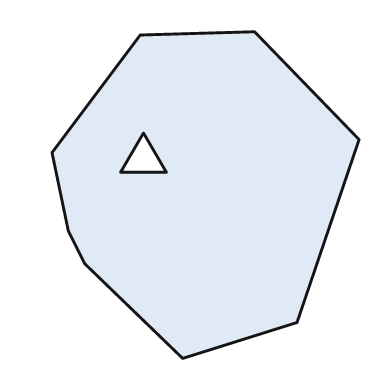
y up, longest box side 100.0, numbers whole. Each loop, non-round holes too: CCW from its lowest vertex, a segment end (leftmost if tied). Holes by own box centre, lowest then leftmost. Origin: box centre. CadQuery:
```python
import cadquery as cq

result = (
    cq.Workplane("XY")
    .moveTo(-7.0, -50.0)
    .lineTo(28.0, -39.0)
    .lineTo(47.0, 17.0)
    .lineTo(15.0, 50.0)
    .lineTo(-20.0, 49.0)
    .lineTo(-47.0, 13.0)
    .lineTo(-42.0, -11.0)
    .lineTo(-37.0, -21.0)
    .close()
    .moveTo(-26.0, 7.0)
    .lineTo(-12.0, 7.0)
    .lineTo(-19.0, 19.0)
    .close()
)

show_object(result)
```